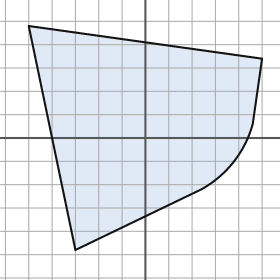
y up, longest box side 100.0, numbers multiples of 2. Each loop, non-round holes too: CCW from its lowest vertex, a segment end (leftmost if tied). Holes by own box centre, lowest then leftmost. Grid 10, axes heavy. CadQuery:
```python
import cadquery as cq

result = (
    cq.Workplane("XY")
    .moveTo(-30.0, -48.0)
    .lineTo(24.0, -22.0)
    .threePointArc((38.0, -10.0), (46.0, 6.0))
    .lineTo(50.0, 34.0)
    .lineTo(-50.0, 48.0)
    .close()
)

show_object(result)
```